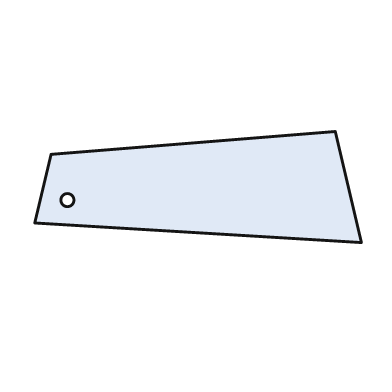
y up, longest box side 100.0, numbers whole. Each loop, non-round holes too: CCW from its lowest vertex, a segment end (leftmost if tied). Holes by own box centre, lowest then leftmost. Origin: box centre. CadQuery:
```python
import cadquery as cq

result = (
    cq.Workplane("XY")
    .moveTo(50.0, -17.0)
    .lineTo(42.0, 17.0)
    .lineTo(-45.0, 10.0)
    .lineTo(-50.0, -11.0)
    .close()
    .moveTo(-40.0, -4.0)
    .circle(2.0)
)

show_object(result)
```